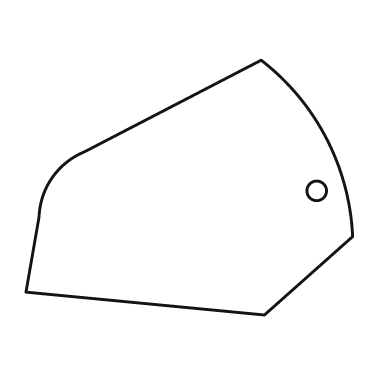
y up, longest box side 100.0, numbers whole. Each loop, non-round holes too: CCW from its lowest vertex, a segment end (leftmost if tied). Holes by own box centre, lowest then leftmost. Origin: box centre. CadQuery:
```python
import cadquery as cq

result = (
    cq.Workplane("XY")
    .moveTo(23.0, -39.0)
    .lineTo(50.0, -15.0)
    .threePointArc((42.0, 15.0), (22.0, 39.0))
    .lineTo(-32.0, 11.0)
    .threePointArc((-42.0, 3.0), (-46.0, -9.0))
    .lineTo(-50.0, -32.0)
    .close()
    .moveTo(39.0, -1.0)
    .circle(3.0)
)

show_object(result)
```